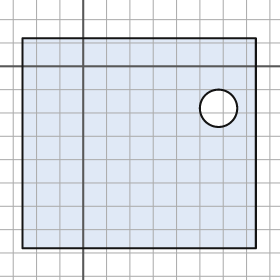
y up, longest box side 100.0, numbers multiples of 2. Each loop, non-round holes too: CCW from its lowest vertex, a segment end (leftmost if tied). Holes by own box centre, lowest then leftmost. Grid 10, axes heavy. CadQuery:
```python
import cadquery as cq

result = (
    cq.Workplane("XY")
    .moveTo(-26.0, -78.0)
    .lineTo(74.0, -78.0)
    .lineTo(74.0, 12.0)
    .lineTo(-26.0, 12.0)
    .close()
    .moveTo(58.0, -18.0)
    .circle(8.0)
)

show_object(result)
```